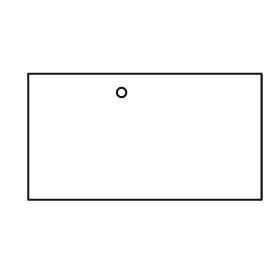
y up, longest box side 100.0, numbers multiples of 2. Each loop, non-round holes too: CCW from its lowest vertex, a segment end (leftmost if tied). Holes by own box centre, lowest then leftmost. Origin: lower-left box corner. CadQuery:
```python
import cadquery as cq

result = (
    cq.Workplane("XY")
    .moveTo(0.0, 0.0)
    .lineTo(100.0, 0.0)
    .lineTo(100.0, 54.0)
    .lineTo(0.0, 54.0)
    .close()
    .moveTo(40.0, 46.0)
    .circle(2.0)
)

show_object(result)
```